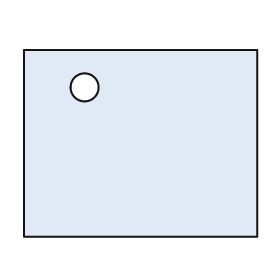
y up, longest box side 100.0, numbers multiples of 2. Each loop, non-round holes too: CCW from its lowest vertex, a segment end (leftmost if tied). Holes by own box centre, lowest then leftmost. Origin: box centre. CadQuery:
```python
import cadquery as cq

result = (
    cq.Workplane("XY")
    .moveTo(-50.0, -40.0)
    .lineTo(50.0, -40.0)
    .lineTo(50.0, 40.0)
    .lineTo(-50.0, 40.0)
    .close()
    .moveTo(-24.0, 24.0)
    .circle(6.0)
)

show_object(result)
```